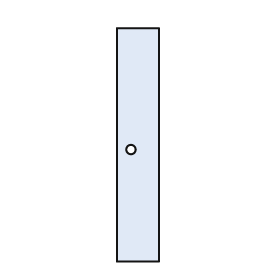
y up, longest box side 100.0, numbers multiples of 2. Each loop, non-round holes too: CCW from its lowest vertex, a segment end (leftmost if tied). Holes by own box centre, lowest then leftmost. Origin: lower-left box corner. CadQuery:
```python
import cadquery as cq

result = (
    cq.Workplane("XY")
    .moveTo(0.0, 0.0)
    .lineTo(18.0, 0.0)
    .lineTo(18.0, 100.0)
    .lineTo(0.0, 100.0)
    .close()
    .moveTo(6.0, 48.0)
    .circle(2.0)
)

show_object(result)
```